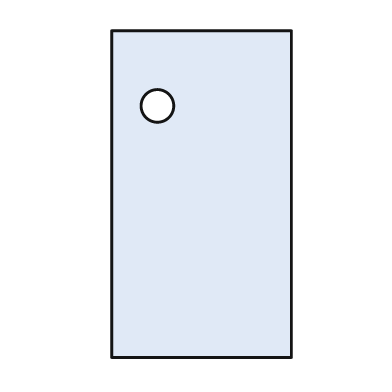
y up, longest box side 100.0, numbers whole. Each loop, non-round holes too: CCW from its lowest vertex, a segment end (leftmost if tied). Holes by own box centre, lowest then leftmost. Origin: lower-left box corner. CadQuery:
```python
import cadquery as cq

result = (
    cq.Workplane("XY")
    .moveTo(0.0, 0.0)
    .lineTo(55.0, 0.0)
    .lineTo(55.0, 100.0)
    .lineTo(0.0, 100.0)
    .close()
    .moveTo(14.0, 77.0)
    .circle(5.0)
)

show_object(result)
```